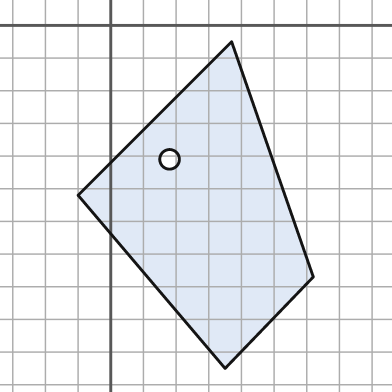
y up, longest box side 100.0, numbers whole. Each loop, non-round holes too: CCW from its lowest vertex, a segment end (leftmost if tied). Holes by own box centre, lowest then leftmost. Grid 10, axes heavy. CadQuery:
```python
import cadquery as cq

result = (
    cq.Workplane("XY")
    .moveTo(35.0, -105.0)
    .lineTo(62.0, -77.0)
    .lineTo(37.0, -5.0)
    .lineTo(-10.0, -52.0)
    .close()
    .moveTo(18.0, -41.0)
    .circle(3.0)
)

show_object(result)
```